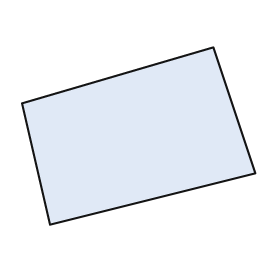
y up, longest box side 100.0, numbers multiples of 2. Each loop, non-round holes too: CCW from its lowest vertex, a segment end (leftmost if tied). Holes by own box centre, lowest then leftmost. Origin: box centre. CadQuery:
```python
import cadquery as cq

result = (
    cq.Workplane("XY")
    .moveTo(-38.0, -38.0)
    .lineTo(50.0, -16.0)
    .lineTo(32.0, 38.0)
    .lineTo(-50.0, 14.0)
    .close()
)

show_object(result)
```